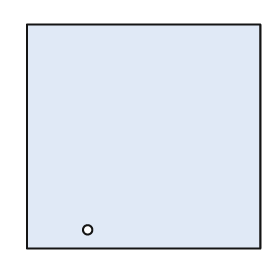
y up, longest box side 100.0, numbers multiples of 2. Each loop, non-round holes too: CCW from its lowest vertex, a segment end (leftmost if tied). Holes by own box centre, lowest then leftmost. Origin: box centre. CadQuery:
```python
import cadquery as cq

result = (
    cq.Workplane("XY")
    .moveTo(-50.0, -48.0)
    .lineTo(50.0, -48.0)
    .lineTo(50.0, 48.0)
    .lineTo(-50.0, 48.0)
    .close()
    .moveTo(-24.0, -40.0)
    .circle(2.0)
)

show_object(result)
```